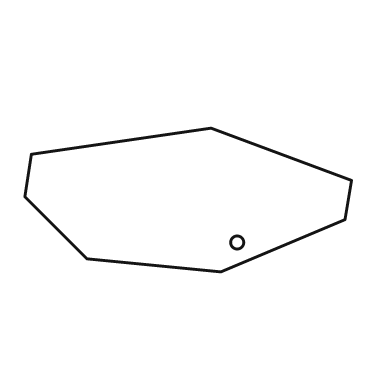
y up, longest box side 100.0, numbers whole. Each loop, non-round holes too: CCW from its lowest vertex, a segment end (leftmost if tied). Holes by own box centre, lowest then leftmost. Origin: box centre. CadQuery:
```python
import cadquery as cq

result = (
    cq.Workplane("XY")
    .moveTo(10.0, -22.0)
    .lineTo(48.0, -6.0)
    .lineTo(50.0, 6.0)
    .lineTo(7.0, 22.0)
    .lineTo(-48.0, 14.0)
    .lineTo(-50.0, 1.0)
    .lineTo(-31.0, -18.0)
    .close()
    .moveTo(15.0, -13.0)
    .circle(2.0)
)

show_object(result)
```